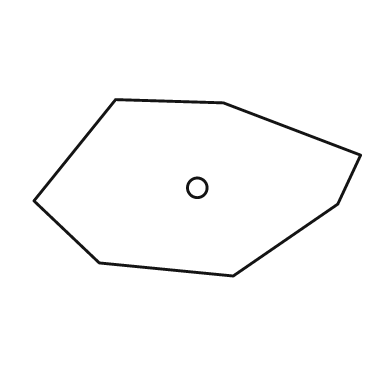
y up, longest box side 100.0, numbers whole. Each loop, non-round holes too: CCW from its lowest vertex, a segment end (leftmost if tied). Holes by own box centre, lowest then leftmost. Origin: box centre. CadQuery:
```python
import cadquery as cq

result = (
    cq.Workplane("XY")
    .moveTo(11.0, -27.0)
    .lineTo(43.0, -5.0)
    .lineTo(50.0, 10.0)
    .lineTo(8.0, 26.0)
    .lineTo(-25.0, 27.0)
    .lineTo(-50.0, -4.0)
    .lineTo(-30.0, -23.0)
    .close()
    .moveTo(0.0, 0.0)
    .circle(3.0)
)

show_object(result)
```